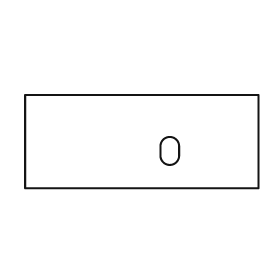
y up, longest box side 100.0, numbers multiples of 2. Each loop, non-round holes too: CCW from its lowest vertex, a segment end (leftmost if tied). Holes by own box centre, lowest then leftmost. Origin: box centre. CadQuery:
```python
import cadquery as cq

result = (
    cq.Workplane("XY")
    .moveTo(-50.0, -20.0)
    .lineTo(50.0, -20.0)
    .lineTo(50.0, 20.0)
    .lineTo(-50.0, 20.0)
    .close()
    .moveTo(8.0, -6.0)
    .threePointArc((12.0, -10.0), (16.0, -6.0))
    .lineTo(16.0, -2.0)
    .threePointArc((12.0, 2.0), (8.0, -2.0))
    .close()
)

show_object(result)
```